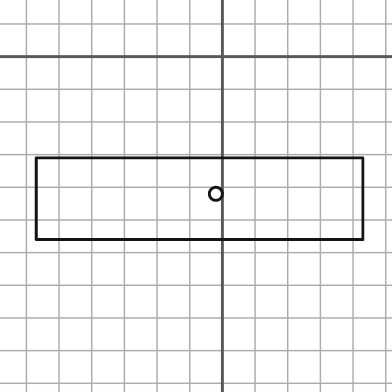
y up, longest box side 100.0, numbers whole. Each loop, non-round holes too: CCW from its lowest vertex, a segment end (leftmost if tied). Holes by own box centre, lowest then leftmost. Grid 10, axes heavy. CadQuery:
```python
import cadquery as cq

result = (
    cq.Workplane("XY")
    .moveTo(-57.0, -56.0)
    .lineTo(43.0, -56.0)
    .lineTo(43.0, -31.0)
    .lineTo(-57.0, -31.0)
    .close()
    .moveTo(-2.0, -42.0)
    .circle(2.0)
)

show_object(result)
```